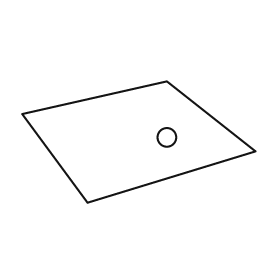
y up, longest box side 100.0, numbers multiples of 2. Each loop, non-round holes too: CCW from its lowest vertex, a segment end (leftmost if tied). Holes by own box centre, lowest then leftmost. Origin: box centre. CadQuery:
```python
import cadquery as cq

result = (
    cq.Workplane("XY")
    .moveTo(-22.0, -26.0)
    .lineTo(50.0, -4.0)
    .lineTo(12.0, 26.0)
    .lineTo(-50.0, 12.0)
    .close()
    .moveTo(12.0, 2.0)
    .circle(4.0)
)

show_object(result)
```